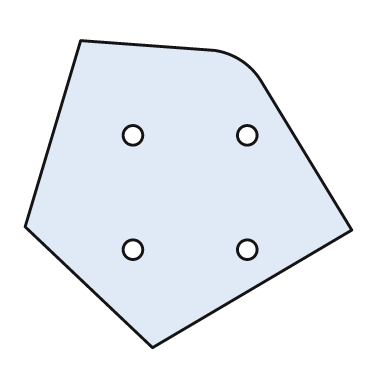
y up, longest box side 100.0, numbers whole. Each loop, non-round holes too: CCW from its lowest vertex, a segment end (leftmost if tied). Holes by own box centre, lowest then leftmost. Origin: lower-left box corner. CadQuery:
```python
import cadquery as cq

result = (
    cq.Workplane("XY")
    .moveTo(39.0, 0.0)
    .lineTo(100.0, 36.0)
    .lineTo(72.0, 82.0)
    .threePointArc((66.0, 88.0), (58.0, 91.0))
    .lineTo(17.0, 94.0)
    .lineTo(0.0, 37.0)
    .close()
    .moveTo(33.0, 30.0)
    .circle(3.0)
    .moveTo(68.0, 30.0)
    .circle(3.0)
    .moveTo(33.0, 65.0)
    .circle(3.0)
    .moveTo(68.0, 65.0)
    .circle(3.0)
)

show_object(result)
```